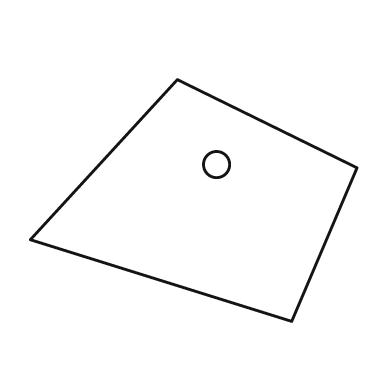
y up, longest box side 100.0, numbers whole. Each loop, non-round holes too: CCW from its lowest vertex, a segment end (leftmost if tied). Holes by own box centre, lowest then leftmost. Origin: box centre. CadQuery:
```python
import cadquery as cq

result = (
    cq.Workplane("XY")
    .moveTo(30.0, -37.0)
    .lineTo(50.0, 10.0)
    .lineTo(-5.0, 37.0)
    .lineTo(-50.0, -12.0)
    .close()
    .moveTo(7.0, 11.0)
    .circle(4.0)
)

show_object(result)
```